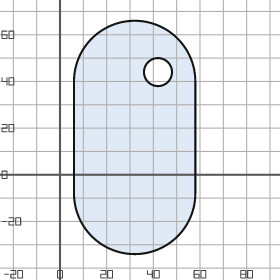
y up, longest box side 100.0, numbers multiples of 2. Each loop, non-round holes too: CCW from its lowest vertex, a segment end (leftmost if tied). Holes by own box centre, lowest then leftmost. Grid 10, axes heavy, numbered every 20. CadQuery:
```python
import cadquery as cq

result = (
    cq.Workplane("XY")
    .moveTo(6.0, -8.0)
    .threePointArc((32.0, -34.0), (58.0, -8.0))
    .lineTo(58.0, 40.0)
    .threePointArc((32.0, 66.0), (6.0, 40.0))
    .close()
    .moveTo(42.0, 44.0)
    .circle(6.0)
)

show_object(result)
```